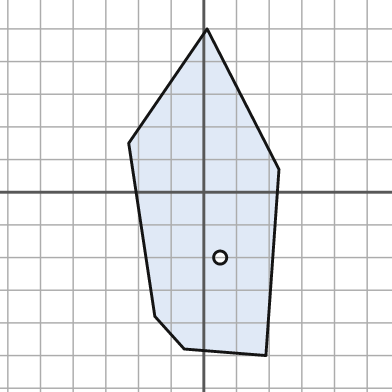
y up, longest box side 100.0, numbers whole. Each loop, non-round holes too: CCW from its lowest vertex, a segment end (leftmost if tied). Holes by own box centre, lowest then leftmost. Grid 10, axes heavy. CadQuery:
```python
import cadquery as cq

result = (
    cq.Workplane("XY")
    .moveTo(19.0, -50.0)
    .lineTo(23.0, 7.0)
    .lineTo(1.0, 50.0)
    .lineTo(-23.0, 15.0)
    .lineTo(-15.0, -38.0)
    .lineTo(-6.0, -48.0)
    .close()
    .moveTo(5.0, -20.0)
    .circle(2.0)
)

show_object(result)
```